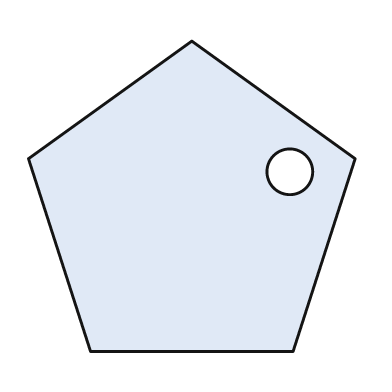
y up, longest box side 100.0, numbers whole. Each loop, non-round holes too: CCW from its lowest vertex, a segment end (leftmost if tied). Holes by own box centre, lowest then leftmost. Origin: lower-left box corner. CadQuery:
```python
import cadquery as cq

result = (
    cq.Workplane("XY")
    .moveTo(19.0, 0.0)
    .lineTo(81.0, 0.0)
    .lineTo(100.0, 59.0)
    .lineTo(50.0, 95.0)
    .lineTo(0.0, 59.0)
    .close()
    .moveTo(80.0, 55.0)
    .circle(7.0)
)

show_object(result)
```